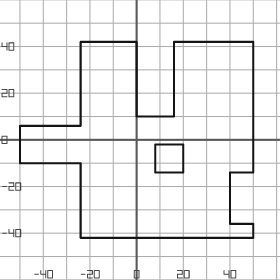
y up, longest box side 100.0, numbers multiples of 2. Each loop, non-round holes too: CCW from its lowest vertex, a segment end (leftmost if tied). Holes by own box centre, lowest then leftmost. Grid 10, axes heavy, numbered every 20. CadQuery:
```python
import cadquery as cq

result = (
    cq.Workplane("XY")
    .moveTo(-24.0, -42.0)
    .lineTo(50.0, -42.0)
    .lineTo(50.0, -36.0)
    .lineTo(40.0, -36.0)
    .lineTo(40.0, -14.0)
    .lineTo(50.0, -14.0)
    .lineTo(50.0, 42.0)
    .lineTo(16.0, 42.0)
    .lineTo(16.0, 10.0)
    .lineTo(0.0, 10.0)
    .lineTo(0.0, 42.0)
    .lineTo(-24.0, 42.0)
    .lineTo(-24.0, 6.0)
    .lineTo(-50.0, 6.0)
    .lineTo(-50.0, -10.0)
    .lineTo(-24.0, -10.0)
    .close()
    .moveTo(8.0, -14.0)
    .lineTo(20.0, -14.0)
    .lineTo(20.0, -2.0)
    .lineTo(8.0, -2.0)
    .close()
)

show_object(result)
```